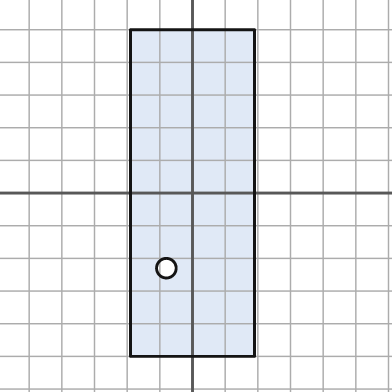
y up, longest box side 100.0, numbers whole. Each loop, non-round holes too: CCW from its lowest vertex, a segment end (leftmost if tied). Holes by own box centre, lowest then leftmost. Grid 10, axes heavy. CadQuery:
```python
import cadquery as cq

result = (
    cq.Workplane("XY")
    .moveTo(-19.0, -50.0)
    .lineTo(19.0, -50.0)
    .lineTo(19.0, 50.0)
    .lineTo(-19.0, 50.0)
    .close()
    .moveTo(-8.0, -23.0)
    .circle(3.0)
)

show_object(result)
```